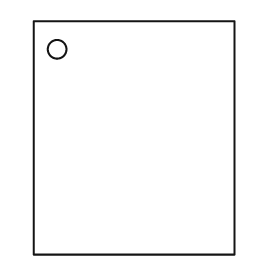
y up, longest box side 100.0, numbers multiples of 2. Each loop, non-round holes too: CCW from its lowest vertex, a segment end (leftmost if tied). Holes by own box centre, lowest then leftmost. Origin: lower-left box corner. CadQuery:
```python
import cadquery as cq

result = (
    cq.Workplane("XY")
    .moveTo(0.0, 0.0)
    .lineTo(86.0, 0.0)
    .lineTo(86.0, 100.0)
    .lineTo(0.0, 100.0)
    .close()
    .moveTo(10.0, 88.0)
    .circle(4.0)
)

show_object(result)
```